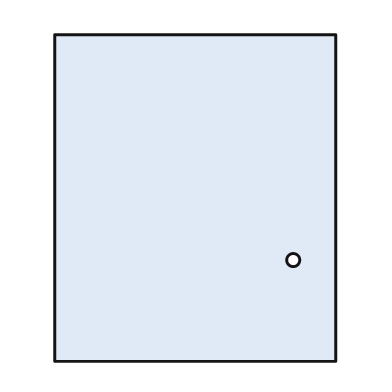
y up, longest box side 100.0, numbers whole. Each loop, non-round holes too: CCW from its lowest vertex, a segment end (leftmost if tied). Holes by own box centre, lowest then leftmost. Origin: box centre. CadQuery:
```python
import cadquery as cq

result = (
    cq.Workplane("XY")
    .moveTo(-43.0, -50.0)
    .lineTo(43.0, -50.0)
    .lineTo(43.0, 50.0)
    .lineTo(-43.0, 50.0)
    .close()
    .moveTo(30.0, -19.0)
    .circle(2.0)
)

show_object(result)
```